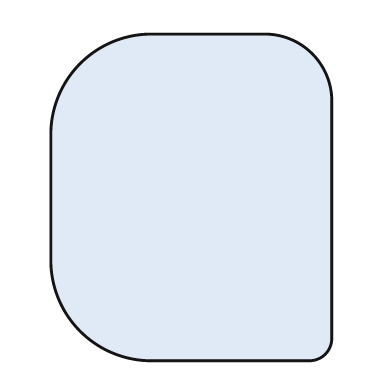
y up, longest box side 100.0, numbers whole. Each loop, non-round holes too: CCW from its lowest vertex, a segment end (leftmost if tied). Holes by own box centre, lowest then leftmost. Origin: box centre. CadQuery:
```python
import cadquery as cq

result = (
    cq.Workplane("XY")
    .moveTo(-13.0, -50.0)
    .lineTo(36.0, -50.0)
    .threePointArc((41.0, -48.0), (43.0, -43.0))
    .lineTo(43.0, 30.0)
    .threePointArc((37.0, 44.0), (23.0, 50.0))
    .lineTo(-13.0, 50.0)
    .threePointArc((-34.0, 41.0), (-43.0, 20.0))
    .lineTo(-43.0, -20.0)
    .threePointArc((-34.0, -41.0), (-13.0, -50.0))
    .close()
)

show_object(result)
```